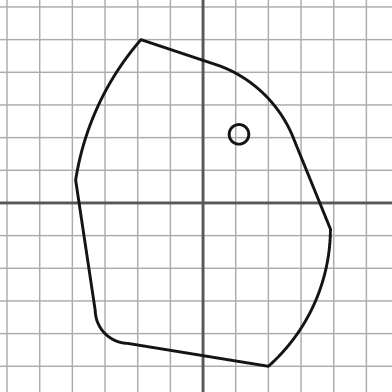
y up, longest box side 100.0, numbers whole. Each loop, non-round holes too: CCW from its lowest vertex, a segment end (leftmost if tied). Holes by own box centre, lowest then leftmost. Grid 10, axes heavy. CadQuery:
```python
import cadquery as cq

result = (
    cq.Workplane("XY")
    .moveTo(20.0, -50.0)
    .threePointArc((34.0, -31.0), (39.0, -8.0))
    .lineTo(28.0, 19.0)
    .threePointArc((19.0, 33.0), (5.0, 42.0))
    .lineTo(-19.0, 50.0)
    .threePointArc((-32.0, 30.0), (-39.0, 7.0))
    .lineTo(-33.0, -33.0)
    .threePointArc((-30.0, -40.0), (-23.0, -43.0))
    .close()
    .moveTo(11.0, 21.0)
    .circle(3.0)
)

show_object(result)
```